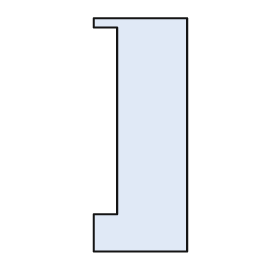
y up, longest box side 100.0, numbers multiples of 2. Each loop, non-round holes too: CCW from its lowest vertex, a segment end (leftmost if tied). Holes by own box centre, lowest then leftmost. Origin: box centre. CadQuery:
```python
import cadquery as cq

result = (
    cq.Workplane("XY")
    .moveTo(-20.0, -50.0)
    .lineTo(20.0, -50.0)
    .lineTo(20.0, 50.0)
    .lineTo(-20.0, 50.0)
    .lineTo(-20.0, 46.0)
    .lineTo(-10.0, 46.0)
    .lineTo(-10.0, -34.0)
    .lineTo(-20.0, -34.0)
    .close()
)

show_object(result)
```